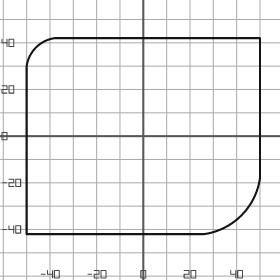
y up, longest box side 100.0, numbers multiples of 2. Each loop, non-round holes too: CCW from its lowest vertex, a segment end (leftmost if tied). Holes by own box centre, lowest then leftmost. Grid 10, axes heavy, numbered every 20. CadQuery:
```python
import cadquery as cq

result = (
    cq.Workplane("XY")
    .moveTo(-50.0, -42.0)
    .lineTo(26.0, -42.0)
    .threePointArc((42.0, -34.0), (50.0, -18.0))
    .lineTo(50.0, 42.0)
    .lineTo(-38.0, 42.0)
    .threePointArc((-46.0, 38.0), (-50.0, 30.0))
    .close()
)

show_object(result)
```